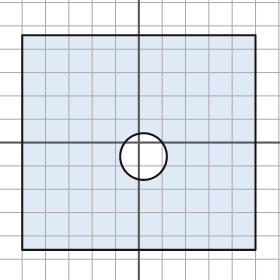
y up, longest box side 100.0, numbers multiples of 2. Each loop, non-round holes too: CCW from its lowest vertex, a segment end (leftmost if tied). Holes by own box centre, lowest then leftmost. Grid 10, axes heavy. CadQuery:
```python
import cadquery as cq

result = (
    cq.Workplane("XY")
    .moveTo(-50.0, -46.0)
    .lineTo(50.0, -46.0)
    .lineTo(50.0, 46.0)
    .lineTo(-50.0, 46.0)
    .close()
    .moveTo(2.0, -6.0)
    .circle(10.0)
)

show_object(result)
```